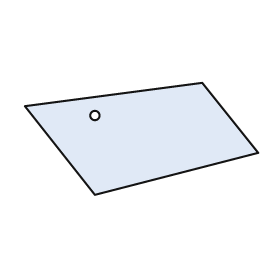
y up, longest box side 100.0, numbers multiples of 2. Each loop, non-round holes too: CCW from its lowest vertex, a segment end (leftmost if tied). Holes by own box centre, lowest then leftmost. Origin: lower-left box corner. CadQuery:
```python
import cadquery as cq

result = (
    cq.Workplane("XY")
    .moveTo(30.0, 0.0)
    .lineTo(100.0, 18.0)
    .lineTo(76.0, 48.0)
    .lineTo(0.0, 38.0)
    .close()
    .moveTo(30.0, 34.0)
    .circle(2.0)
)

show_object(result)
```